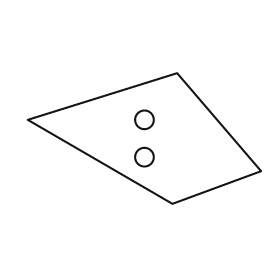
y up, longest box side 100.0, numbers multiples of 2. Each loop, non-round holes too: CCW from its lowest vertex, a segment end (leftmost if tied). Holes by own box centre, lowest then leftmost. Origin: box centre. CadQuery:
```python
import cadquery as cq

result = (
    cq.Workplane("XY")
    .moveTo(12.0, -28.0)
    .lineTo(50.0, -14.0)
    .lineTo(14.0, 28.0)
    .lineTo(-50.0, 8.0)
    .close()
    .moveTo(0.0, -8.0)
    .circle(4.0)
    .moveTo(0.0, 8.0)
    .circle(4.0)
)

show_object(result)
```